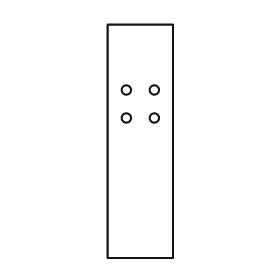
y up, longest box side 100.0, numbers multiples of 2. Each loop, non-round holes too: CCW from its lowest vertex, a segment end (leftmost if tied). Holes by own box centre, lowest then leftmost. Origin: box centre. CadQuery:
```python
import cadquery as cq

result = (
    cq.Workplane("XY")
    .moveTo(-14.0, -50.0)
    .lineTo(14.0, -50.0)
    .lineTo(14.0, 50.0)
    .lineTo(-14.0, 50.0)
    .close()
    .moveTo(-6.0, 10.0)
    .circle(2.0)
    .moveTo(6.0, 10.0)
    .circle(2.0)
    .moveTo(-6.0, 22.0)
    .circle(2.0)
    .moveTo(6.0, 22.0)
    .circle(2.0)
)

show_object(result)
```